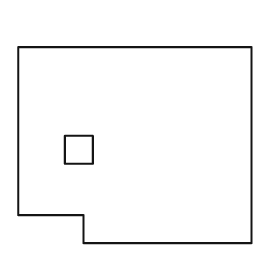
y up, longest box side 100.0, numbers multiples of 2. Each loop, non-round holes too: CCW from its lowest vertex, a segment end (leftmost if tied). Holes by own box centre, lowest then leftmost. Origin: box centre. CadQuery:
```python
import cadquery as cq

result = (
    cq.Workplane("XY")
    .moveTo(-22.0, -42.0)
    .lineTo(50.0, -42.0)
    .lineTo(50.0, 42.0)
    .lineTo(-50.0, 42.0)
    .lineTo(-50.0, -30.0)
    .lineTo(-22.0, -30.0)
    .close()
    .moveTo(-30.0, -8.0)
    .lineTo(-18.0, -8.0)
    .lineTo(-18.0, 4.0)
    .lineTo(-30.0, 4.0)
    .close()
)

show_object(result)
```